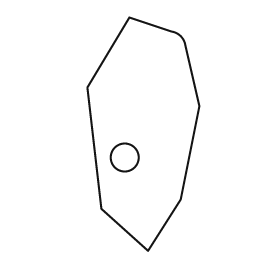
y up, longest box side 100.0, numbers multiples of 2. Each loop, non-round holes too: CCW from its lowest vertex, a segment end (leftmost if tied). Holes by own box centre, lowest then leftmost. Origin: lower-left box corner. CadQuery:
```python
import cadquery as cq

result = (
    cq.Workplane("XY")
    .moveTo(26.0, 0.0)
    .lineTo(40.0, 22.0)
    .lineTo(48.0, 62.0)
    .lineTo(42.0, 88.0)
    .threePointArc((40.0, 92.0), (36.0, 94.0))
    .lineTo(18.0, 100.0)
    .lineTo(0.0, 70.0)
    .lineTo(6.0, 18.0)
    .close()
    .moveTo(16.0, 40.0)
    .circle(6.0)
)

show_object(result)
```